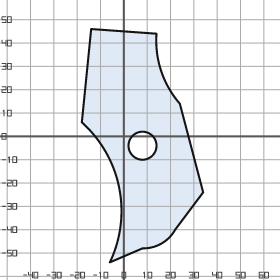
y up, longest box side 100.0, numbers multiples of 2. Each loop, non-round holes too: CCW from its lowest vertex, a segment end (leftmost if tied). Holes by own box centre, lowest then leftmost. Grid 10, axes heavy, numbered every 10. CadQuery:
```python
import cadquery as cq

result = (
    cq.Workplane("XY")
    .moveTo(-6.0, -54.0)
    .lineTo(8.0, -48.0)
    .threePointArc((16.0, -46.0), (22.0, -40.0))
    .lineTo(34.0, -24.0)
    .lineTo(24.0, 14.0)
    .threePointArc((16.0, 28.0), (14.0, 44.0))
    .lineTo(-14.0, 46.0)
    .lineTo(-18.0, 6.0)
    .threePointArc((-2.0, -22.0), (-6.0, -54.0))
    .close()
    .moveTo(8.0, -4.0)
    .circle(6.0)
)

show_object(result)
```